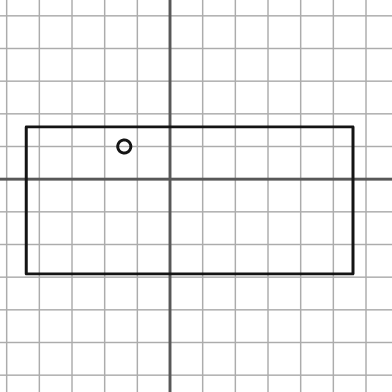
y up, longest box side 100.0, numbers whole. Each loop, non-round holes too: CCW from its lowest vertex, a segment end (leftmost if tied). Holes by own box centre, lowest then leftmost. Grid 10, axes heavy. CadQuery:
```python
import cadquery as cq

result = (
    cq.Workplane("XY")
    .moveTo(-44.0, -29.0)
    .lineTo(56.0, -29.0)
    .lineTo(56.0, 16.0)
    .lineTo(-44.0, 16.0)
    .close()
    .moveTo(-14.0, 10.0)
    .circle(2.0)
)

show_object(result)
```